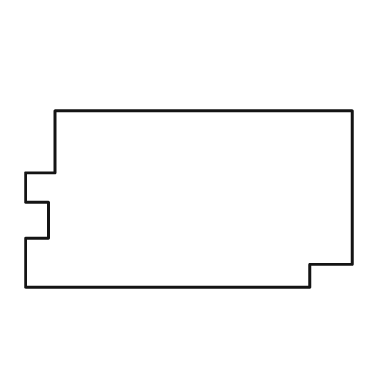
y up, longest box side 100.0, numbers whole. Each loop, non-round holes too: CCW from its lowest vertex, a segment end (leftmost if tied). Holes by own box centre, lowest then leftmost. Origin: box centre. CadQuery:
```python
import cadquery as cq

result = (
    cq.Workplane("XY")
    .moveTo(-50.0, -27.0)
    .lineTo(37.0, -27.0)
    .lineTo(37.0, -20.0)
    .lineTo(50.0, -20.0)
    .lineTo(50.0, 27.0)
    .lineTo(-41.0, 27.0)
    .lineTo(-41.0, 8.0)
    .lineTo(-50.0, 8.0)
    .lineTo(-50.0, -1.0)
    .lineTo(-43.0, -1.0)
    .lineTo(-43.0, -12.0)
    .lineTo(-50.0, -12.0)
    .close()
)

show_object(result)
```